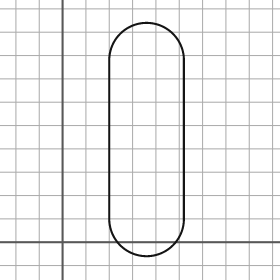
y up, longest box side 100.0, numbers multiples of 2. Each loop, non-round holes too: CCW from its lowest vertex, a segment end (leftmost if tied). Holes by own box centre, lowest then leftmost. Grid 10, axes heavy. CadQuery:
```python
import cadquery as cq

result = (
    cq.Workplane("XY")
    .moveTo(20.0, 10.0)
    .threePointArc((36.0, -6.0), (52.0, 10.0))
    .lineTo(52.0, 78.0)
    .threePointArc((36.0, 94.0), (20.0, 78.0))
    .close()
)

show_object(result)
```